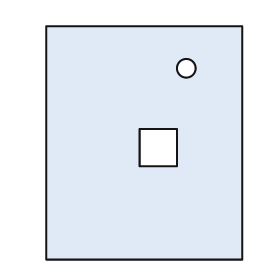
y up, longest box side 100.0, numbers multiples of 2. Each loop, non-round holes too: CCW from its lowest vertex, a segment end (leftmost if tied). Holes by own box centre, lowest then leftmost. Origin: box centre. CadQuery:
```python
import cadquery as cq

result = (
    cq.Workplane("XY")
    .moveTo(-42.0, -50.0)
    .lineTo(42.0, -50.0)
    .lineTo(42.0, 50.0)
    .lineTo(-42.0, 50.0)
    .close()
    .moveTo(-2.0, -10.0)
    .lineTo(14.0, -10.0)
    .lineTo(14.0, 6.0)
    .lineTo(-2.0, 6.0)
    .close()
    .moveTo(18.0, 32.0)
    .circle(4.0)
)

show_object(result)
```